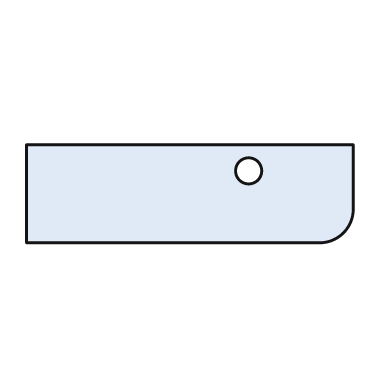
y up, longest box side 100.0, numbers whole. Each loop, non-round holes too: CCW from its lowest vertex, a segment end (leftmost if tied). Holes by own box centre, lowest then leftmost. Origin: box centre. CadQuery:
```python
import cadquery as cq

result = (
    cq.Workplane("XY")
    .moveTo(-50.0, -15.0)
    .lineTo(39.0, -15.0)
    .threePointArc((47.0, -12.0), (50.0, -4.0))
    .lineTo(50.0, 15.0)
    .lineTo(-50.0, 15.0)
    .close()
    .moveTo(18.0, 7.0)
    .circle(4.0)
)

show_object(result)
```